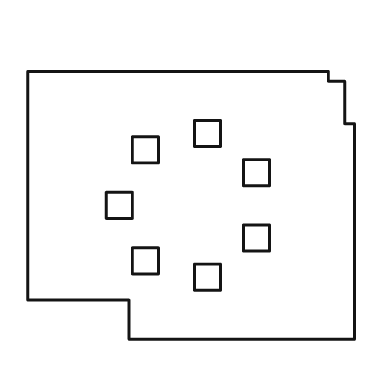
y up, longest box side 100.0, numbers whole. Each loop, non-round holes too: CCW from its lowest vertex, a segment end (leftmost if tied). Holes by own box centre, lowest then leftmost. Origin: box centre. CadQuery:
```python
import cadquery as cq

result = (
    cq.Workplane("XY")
    .moveTo(-19.0, -41.0)
    .lineTo(50.0, -41.0)
    .lineTo(50.0, 25.0)
    .lineTo(47.0, 25.0)
    .lineTo(47.0, 38.0)
    .lineTo(42.0, 38.0)
    .lineTo(42.0, 41.0)
    .lineTo(-50.0, 41.0)
    .lineTo(-50.0, -29.0)
    .lineTo(-19.0, -29.0)
    .close()
    .moveTo(1.0, -26.0)
    .lineTo(9.0, -26.0)
    .lineTo(9.0, -18.0)
    .lineTo(1.0, -18.0)
    .close()
    .moveTo(-18.0, -21.0)
    .lineTo(-10.0, -21.0)
    .lineTo(-10.0, -13.0)
    .lineTo(-18.0, -13.0)
    .close()
    .moveTo(16.0, -14.0)
    .lineTo(24.0, -14.0)
    .lineTo(24.0, -6.0)
    .lineTo(16.0, -6.0)
    .close()
    .moveTo(-26.0, -4.0)
    .lineTo(-18.0, -4.0)
    .lineTo(-18.0, 4.0)
    .lineTo(-26.0, 4.0)
    .close()
    .moveTo(16.0, 6.0)
    .lineTo(24.0, 6.0)
    .lineTo(24.0, 14.0)
    .lineTo(16.0, 14.0)
    .close()
    .moveTo(-18.0, 13.0)
    .lineTo(-10.0, 13.0)
    .lineTo(-10.0, 21.0)
    .lineTo(-18.0, 21.0)
    .close()
    .moveTo(1.0, 18.0)
    .lineTo(9.0, 18.0)
    .lineTo(9.0, 26.0)
    .lineTo(1.0, 26.0)
    .close()
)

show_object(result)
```